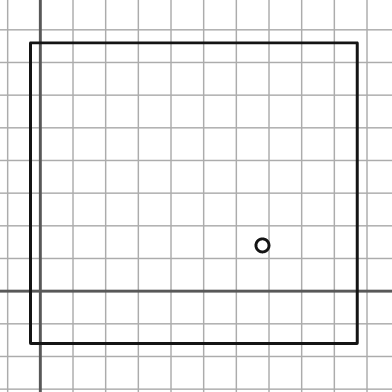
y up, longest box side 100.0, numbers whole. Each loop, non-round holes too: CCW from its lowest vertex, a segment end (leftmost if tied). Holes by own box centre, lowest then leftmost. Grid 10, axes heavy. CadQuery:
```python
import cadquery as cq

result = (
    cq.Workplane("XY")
    .moveTo(-3.0, -16.0)
    .lineTo(97.0, -16.0)
    .lineTo(97.0, 76.0)
    .lineTo(-3.0, 76.0)
    .close()
    .moveTo(68.0, 14.0)
    .circle(2.0)
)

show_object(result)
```